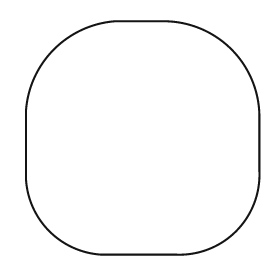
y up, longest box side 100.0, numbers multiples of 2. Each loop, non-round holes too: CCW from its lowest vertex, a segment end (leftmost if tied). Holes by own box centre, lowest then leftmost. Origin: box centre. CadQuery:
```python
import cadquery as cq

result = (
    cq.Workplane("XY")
    .moveTo(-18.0, -50.0)
    .lineTo(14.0, -50.0)
    .threePointArc((40.0, -40.0), (50.0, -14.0))
    .lineTo(50.0, 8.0)
    .threePointArc((38.0, 38.0), (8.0, 50.0))
    .lineTo(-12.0, 50.0)
    .threePointArc((-38.0, 38.0), (-50.0, 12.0))
    .lineTo(-50.0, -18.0)
    .threePointArc((-40.0, -40.0), (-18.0, -50.0))
    .close()
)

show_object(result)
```